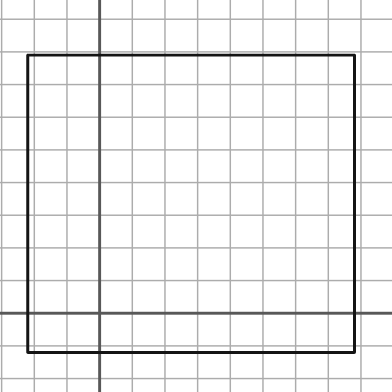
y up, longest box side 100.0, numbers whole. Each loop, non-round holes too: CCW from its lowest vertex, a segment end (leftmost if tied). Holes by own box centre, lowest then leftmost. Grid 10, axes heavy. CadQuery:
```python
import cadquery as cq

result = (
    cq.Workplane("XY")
    .moveTo(-22.0, -12.0)
    .lineTo(78.0, -12.0)
    .lineTo(78.0, 79.0)
    .lineTo(-22.0, 79.0)
    .close()
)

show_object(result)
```